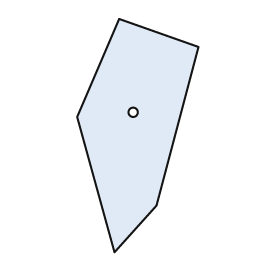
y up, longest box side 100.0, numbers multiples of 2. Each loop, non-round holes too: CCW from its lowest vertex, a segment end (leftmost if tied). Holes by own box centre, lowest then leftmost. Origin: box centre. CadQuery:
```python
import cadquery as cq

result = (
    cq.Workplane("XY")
    .moveTo(-10.0, -50.0)
    .lineTo(8.0, -30.0)
    .lineTo(26.0, 38.0)
    .lineTo(-8.0, 50.0)
    .lineTo(-26.0, 8.0)
    .close()
    .moveTo(-2.0, 10.0)
    .circle(2.0)
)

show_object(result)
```